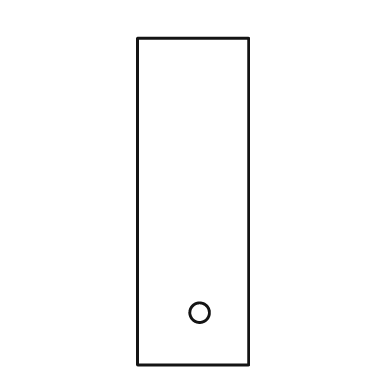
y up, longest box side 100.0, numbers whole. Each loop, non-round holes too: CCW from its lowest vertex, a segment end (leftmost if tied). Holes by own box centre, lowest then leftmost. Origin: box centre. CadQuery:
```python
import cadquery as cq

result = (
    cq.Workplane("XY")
    .moveTo(-17.0, -50.0)
    .lineTo(17.0, -50.0)
    .lineTo(17.0, 50.0)
    .lineTo(-17.0, 50.0)
    .close()
    .moveTo(2.0, -34.0)
    .circle(3.0)
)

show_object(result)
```